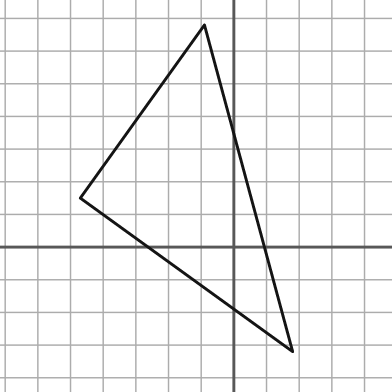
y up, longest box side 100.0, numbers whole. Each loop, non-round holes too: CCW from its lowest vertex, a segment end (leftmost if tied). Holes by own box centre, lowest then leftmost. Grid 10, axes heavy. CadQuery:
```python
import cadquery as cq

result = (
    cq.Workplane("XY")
    .moveTo(18.0, -32.0)
    .lineTo(-9.0, 68.0)
    .lineTo(-47.0, 15.0)
    .close()
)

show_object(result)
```